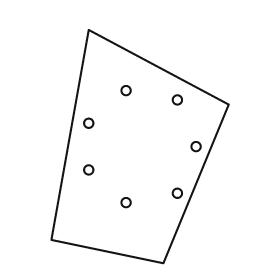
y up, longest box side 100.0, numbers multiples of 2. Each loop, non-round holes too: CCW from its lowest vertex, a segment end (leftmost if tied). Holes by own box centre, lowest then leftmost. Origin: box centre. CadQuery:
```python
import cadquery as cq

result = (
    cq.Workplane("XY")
    .moveTo(10.0, -50.0)
    .lineTo(38.0, 18.0)
    .lineTo(-22.0, 50.0)
    .lineTo(-38.0, -40.0)
    .close()
    .moveTo(-6.0, -24.0)
    .circle(2.0)
    .moveTo(16.0, -20.0)
    .circle(2.0)
    .moveTo(-22.0, -10.0)
    .circle(2.0)
    .moveTo(24.0, 0.0)
    .circle(2.0)
    .moveTo(-22.0, 10.0)
    .circle(2.0)
    .moveTo(16.0, 20.0)
    .circle(2.0)
    .moveTo(-6.0, 24.0)
    .circle(2.0)
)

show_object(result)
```